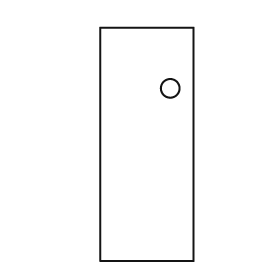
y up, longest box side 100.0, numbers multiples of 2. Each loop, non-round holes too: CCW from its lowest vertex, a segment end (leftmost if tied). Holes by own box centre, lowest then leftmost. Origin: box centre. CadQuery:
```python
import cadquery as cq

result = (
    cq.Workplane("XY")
    .moveTo(-20.0, -50.0)
    .lineTo(20.0, -50.0)
    .lineTo(20.0, 50.0)
    .lineTo(-20.0, 50.0)
    .close()
    .moveTo(10.0, 24.0)
    .circle(4.0)
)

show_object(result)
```